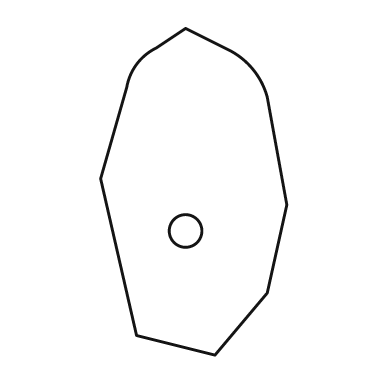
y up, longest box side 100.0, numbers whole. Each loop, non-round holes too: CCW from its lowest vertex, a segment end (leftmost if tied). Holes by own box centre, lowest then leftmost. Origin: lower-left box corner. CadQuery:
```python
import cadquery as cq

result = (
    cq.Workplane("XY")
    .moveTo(35.0, 0.0)
    .lineTo(51.0, 19.0)
    .lineTo(57.0, 46.0)
    .lineTo(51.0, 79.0)
    .threePointArc((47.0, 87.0), (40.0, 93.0))
    .lineTo(26.0, 100.0)
    .lineTo(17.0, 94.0)
    .threePointArc((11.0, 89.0), (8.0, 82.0))
    .lineTo(0.0, 54.0)
    .lineTo(11.0, 6.0)
    .close()
    .moveTo(26.0, 38.0)
    .circle(5.0)
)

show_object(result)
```